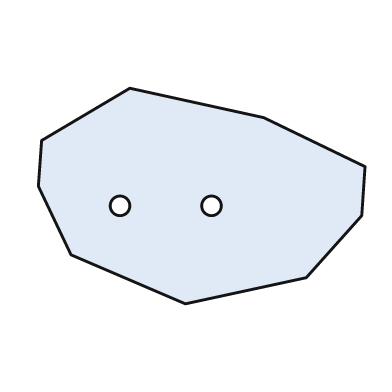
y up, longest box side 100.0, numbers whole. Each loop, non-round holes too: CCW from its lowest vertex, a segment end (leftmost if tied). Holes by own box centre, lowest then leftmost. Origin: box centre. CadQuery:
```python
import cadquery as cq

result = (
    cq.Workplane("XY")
    .moveTo(-5.0, -33.0)
    .lineTo(32.0, -25.0)
    .lineTo(49.0, -6.0)
    .lineTo(50.0, 9.0)
    .lineTo(19.0, 24.0)
    .lineTo(-22.0, 33.0)
    .lineTo(-49.0, 17.0)
    .lineTo(-50.0, 3.0)
    .lineTo(-40.0, -18.0)
    .close()
    .moveTo(-25.0, -3.0)
    .circle(3.0)
    .moveTo(3.0, -3.0)
    .circle(3.0)
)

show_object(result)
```